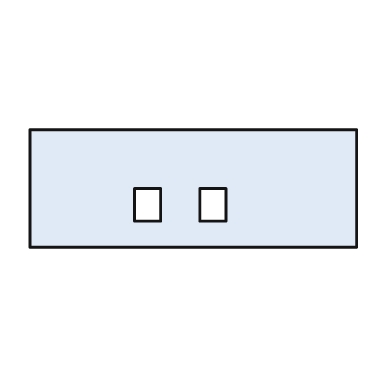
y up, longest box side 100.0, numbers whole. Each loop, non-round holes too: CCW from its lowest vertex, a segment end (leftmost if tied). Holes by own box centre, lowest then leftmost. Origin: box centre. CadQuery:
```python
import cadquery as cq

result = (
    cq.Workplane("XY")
    .moveTo(-50.0, -18.0)
    .lineTo(50.0, -18.0)
    .lineTo(50.0, 18.0)
    .lineTo(-50.0, 18.0)
    .close()
    .moveTo(-18.0, -10.0)
    .lineTo(-10.0, -10.0)
    .lineTo(-10.0, 0.0)
    .lineTo(-18.0, 0.0)
    .close()
    .moveTo(2.0, -10.0)
    .lineTo(10.0, -10.0)
    .lineTo(10.0, 0.0)
    .lineTo(2.0, 0.0)
    .close()
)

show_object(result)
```